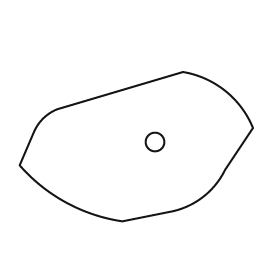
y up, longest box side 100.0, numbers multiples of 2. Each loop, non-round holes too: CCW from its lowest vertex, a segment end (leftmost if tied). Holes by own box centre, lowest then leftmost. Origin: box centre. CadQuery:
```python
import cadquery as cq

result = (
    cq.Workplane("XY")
    .moveTo(-6.0, -32.0)
    .lineTo(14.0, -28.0)
    .threePointArc((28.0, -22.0), (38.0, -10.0))
    .lineTo(50.0, 8.0)
    .threePointArc((38.0, 24.0), (20.0, 32.0))
    .lineTo(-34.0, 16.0)
    .threePointArc((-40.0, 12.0), (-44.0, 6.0))
    .lineTo(-50.0, -8.0)
    .threePointArc((-30.0, -24.0), (-6.0, -32.0))
    .close()
    .moveTo(8.0, 2.0)
    .circle(4.0)
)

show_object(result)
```